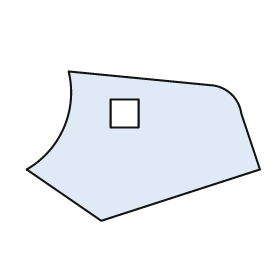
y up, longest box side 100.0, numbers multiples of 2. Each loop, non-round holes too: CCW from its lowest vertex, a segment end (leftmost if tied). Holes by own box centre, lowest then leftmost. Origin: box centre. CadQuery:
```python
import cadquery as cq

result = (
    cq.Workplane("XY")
    .moveTo(-18.0, -32.0)
    .lineTo(50.0, -10.0)
    .lineTo(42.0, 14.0)
    .threePointArc((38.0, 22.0), (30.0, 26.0))
    .lineTo(-32.0, 32.0)
    .threePointArc((-34.0, 8.0), (-50.0, -10.0))
    .close()
    .moveTo(-14.0, 8.0)
    .lineTo(-2.0, 8.0)
    .lineTo(-2.0, 20.0)
    .lineTo(-14.0, 20.0)
    .close()
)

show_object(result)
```